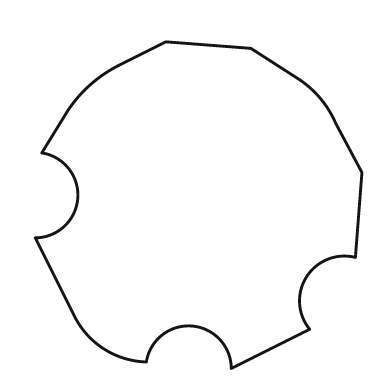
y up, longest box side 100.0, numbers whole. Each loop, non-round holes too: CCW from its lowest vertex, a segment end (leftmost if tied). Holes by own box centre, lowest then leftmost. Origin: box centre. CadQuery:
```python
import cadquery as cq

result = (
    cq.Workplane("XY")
    .moveTo(10.0, -50.0)
    .lineTo(34.0, -38.0)
    .threePointArc((33.0, -22.0), (48.0, -16.0))
    .lineTo(50.0, 10.0)
    .lineTo(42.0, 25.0)
    .threePointArc((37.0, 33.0), (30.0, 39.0))
    .lineTo(16.0, 48.0)
    .lineTo(-10.0, 50.0)
    .lineTo(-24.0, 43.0)
    .threePointArc((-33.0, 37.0), (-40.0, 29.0))
    .lineTo(-48.0, 16.0)
    .threePointArc((-37.0, 2.0), (-50.0, -10.0))
    .lineTo(-38.0, -34.0)
    .threePointArc((-29.0, -44.0), (-16.0, -48.0))
    .threePointArc((-2.0, -37.0), (10.0, -50.0))
    .close()
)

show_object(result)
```